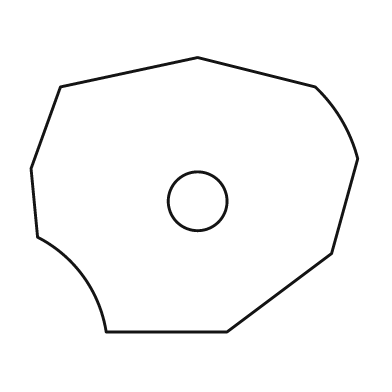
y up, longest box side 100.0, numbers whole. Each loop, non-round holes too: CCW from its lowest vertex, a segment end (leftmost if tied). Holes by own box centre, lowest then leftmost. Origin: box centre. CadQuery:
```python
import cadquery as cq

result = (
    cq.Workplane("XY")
    .moveTo(-27.0, -42.0)
    .lineTo(10.0, -42.0)
    .lineTo(42.0, -18.0)
    .lineTo(50.0, 11.0)
    .threePointArc((45.0, 23.0), (37.0, 33.0))
    .lineTo(1.0, 42.0)
    .lineTo(-41.0, 33.0)
    .lineTo(-50.0, 8.0)
    .lineTo(-48.0, -13.0)
    .threePointArc((-34.0, -25.0), (-27.0, -42.0))
    .close()
    .moveTo(1.0, -2.0)
    .circle(9.0)
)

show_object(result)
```